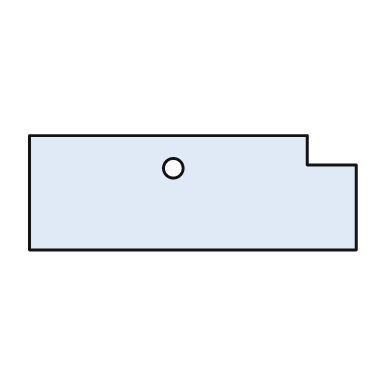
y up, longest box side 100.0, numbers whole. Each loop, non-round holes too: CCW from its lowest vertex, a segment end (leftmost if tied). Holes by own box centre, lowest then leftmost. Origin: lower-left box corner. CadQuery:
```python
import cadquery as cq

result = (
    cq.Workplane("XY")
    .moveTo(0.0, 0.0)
    .lineTo(100.0, 0.0)
    .lineTo(100.0, 26.0)
    .lineTo(85.0, 26.0)
    .lineTo(85.0, 35.0)
    .lineTo(0.0, 35.0)
    .close()
    .moveTo(44.0, 25.0)
    .circle(3.0)
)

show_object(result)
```